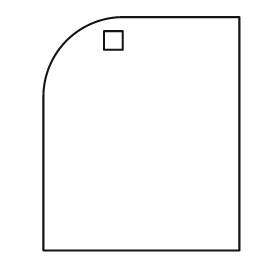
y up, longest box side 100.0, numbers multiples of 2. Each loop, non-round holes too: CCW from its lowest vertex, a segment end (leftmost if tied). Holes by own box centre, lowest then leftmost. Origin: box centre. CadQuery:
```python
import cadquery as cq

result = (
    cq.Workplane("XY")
    .moveTo(-42.0, -50.0)
    .lineTo(42.0, -50.0)
    .lineTo(42.0, 50.0)
    .lineTo(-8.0, 50.0)
    .threePointArc((-32.0, 40.0), (-42.0, 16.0))
    .close()
    .moveTo(-16.0, 36.0)
    .lineTo(-8.0, 36.0)
    .lineTo(-8.0, 44.0)
    .lineTo(-16.0, 44.0)
    .close()
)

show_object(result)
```